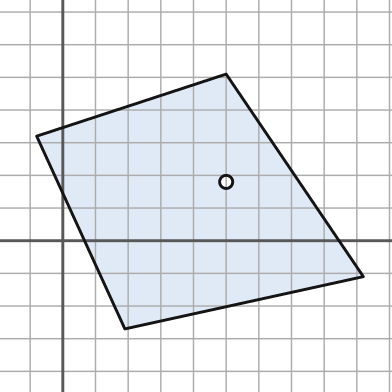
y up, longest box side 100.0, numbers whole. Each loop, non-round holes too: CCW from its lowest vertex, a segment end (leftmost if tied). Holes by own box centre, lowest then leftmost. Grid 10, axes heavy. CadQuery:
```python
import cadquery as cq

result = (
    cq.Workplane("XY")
    .moveTo(19.0, -27.0)
    .lineTo(92.0, -11.0)
    .lineTo(50.0, 51.0)
    .lineTo(-8.0, 32.0)
    .close()
    .moveTo(50.0, 18.0)
    .circle(2.0)
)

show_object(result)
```